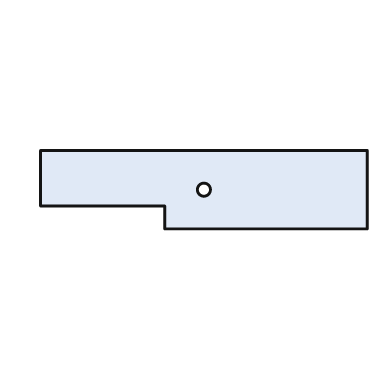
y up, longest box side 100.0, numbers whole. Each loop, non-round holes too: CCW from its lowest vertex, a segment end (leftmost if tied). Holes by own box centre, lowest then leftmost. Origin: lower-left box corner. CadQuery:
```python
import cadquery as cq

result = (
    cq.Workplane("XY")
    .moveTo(38.0, 0.0)
    .lineTo(100.0, 0.0)
    .lineTo(100.0, 24.0)
    .lineTo(0.0, 24.0)
    .lineTo(0.0, 7.0)
    .lineTo(38.0, 7.0)
    .close()
    .moveTo(50.0, 12.0)
    .circle(2.0)
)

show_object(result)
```